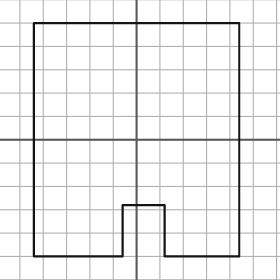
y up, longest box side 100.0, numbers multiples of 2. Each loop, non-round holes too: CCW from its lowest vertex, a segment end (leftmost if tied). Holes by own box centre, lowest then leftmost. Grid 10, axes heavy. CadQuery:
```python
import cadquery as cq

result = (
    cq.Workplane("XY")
    .moveTo(-44.0, -50.0)
    .lineTo(-6.0, -50.0)
    .lineTo(-6.0, -28.0)
    .lineTo(12.0, -28.0)
    .lineTo(12.0, -50.0)
    .lineTo(44.0, -50.0)
    .lineTo(44.0, 50.0)
    .lineTo(-44.0, 50.0)
    .close()
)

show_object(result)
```